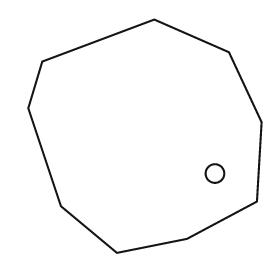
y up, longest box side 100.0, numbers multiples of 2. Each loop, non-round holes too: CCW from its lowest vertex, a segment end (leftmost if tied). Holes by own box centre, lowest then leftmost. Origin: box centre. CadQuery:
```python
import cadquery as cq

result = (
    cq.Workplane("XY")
    .moveTo(-12.0, -50.0)
    .lineTo(18.0, -44.0)
    .lineTo(48.0, -28.0)
    .lineTo(50.0, 6.0)
    .lineTo(36.0, 36.0)
    .lineTo(4.0, 50.0)
    .lineTo(-44.0, 32.0)
    .lineTo(-50.0, 12.0)
    .lineTo(-36.0, -30.0)
    .close()
    .moveTo(30.0, -16.0)
    .circle(4.0)
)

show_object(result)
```